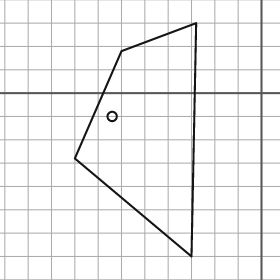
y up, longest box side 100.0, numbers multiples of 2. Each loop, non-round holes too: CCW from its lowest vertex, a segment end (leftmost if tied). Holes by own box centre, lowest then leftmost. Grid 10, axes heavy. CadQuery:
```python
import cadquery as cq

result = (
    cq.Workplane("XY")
    .moveTo(-30.0, -70.0)
    .lineTo(-28.0, 30.0)
    .lineTo(-60.0, 18.0)
    .lineTo(-80.0, -28.0)
    .close()
    .moveTo(-64.0, -10.0)
    .circle(2.0)
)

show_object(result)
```